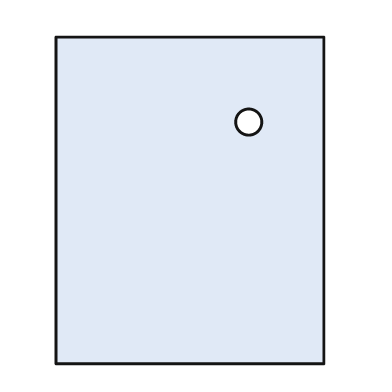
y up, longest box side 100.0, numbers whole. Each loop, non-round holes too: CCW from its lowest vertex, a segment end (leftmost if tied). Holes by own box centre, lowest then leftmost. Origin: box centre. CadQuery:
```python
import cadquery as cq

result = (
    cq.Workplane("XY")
    .moveTo(-41.0, -50.0)
    .lineTo(41.0, -50.0)
    .lineTo(41.0, 50.0)
    .lineTo(-41.0, 50.0)
    .close()
    .moveTo(18.0, 24.0)
    .circle(4.0)
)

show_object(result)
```